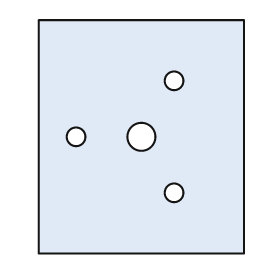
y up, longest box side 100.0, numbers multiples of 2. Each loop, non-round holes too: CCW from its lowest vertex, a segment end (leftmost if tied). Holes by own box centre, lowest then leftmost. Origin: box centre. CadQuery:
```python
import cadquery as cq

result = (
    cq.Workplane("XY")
    .moveTo(-44.0, -50.0)
    .lineTo(44.0, -50.0)
    .lineTo(44.0, 50.0)
    .lineTo(-44.0, 50.0)
    .close()
    .moveTo(14.0, -24.0)
    .circle(4.0)
    .moveTo(-28.0, 0.0)
    .circle(4.0)
    .moveTo(0.0, 0.0)
    .circle(6.0)
    .moveTo(14.0, 24.0)
    .circle(4.0)
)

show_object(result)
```